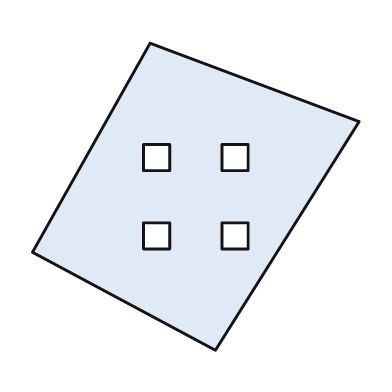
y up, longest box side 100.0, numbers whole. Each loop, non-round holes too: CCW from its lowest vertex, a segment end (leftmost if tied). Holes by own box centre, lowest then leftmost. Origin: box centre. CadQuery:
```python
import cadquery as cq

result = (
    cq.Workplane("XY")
    .moveTo(6.0, -47.0)
    .lineTo(50.0, 23.0)
    .lineTo(-14.0, 47.0)
    .lineTo(-50.0, -17.0)
    .close()
    .moveTo(-16.0, -16.0)
    .lineTo(-8.0, -16.0)
    .lineTo(-8.0, -8.0)
    .lineTo(-16.0, -8.0)
    .close()
    .moveTo(8.0, -16.0)
    .lineTo(16.0, -16.0)
    .lineTo(16.0, -8.0)
    .lineTo(8.0, -8.0)
    .close()
    .moveTo(-16.0, 8.0)
    .lineTo(-8.0, 8.0)
    .lineTo(-8.0, 16.0)
    .lineTo(-16.0, 16.0)
    .close()
    .moveTo(8.0, 8.0)
    .lineTo(16.0, 8.0)
    .lineTo(16.0, 16.0)
    .lineTo(8.0, 16.0)
    .close()
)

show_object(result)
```